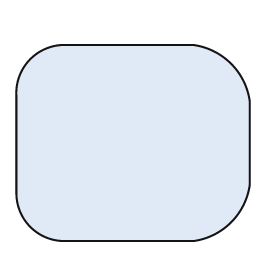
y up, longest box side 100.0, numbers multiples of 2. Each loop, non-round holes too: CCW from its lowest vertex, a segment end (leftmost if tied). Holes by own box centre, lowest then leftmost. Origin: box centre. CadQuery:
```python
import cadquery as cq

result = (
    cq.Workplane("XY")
    .moveTo(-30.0, -42.0)
    .lineTo(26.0, -42.0)
    .threePointArc((42.0, -34.0), (50.0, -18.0))
    .lineTo(50.0, 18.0)
    .threePointArc((42.0, 34.0), (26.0, 42.0))
    .lineTo(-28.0, 42.0)
    .threePointArc((-44.0, 36.0), (-50.0, 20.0))
    .lineTo(-50.0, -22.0)
    .threePointArc((-44.0, -36.0), (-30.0, -42.0))
    .close()
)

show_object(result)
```